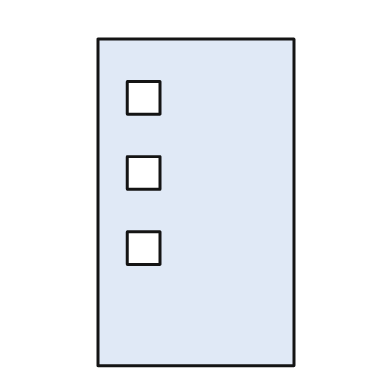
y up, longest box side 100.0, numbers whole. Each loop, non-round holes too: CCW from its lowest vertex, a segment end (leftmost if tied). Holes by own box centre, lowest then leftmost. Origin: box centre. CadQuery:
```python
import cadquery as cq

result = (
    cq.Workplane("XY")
    .moveTo(-30.0, -50.0)
    .lineTo(30.0, -50.0)
    .lineTo(30.0, 50.0)
    .lineTo(-30.0, 50.0)
    .close()
    .moveTo(-21.0, -19.0)
    .lineTo(-11.0, -19.0)
    .lineTo(-11.0, -9.0)
    .lineTo(-21.0, -9.0)
    .close()
    .moveTo(-21.0, 4.0)
    .lineTo(-11.0, 4.0)
    .lineTo(-11.0, 14.0)
    .lineTo(-21.0, 14.0)
    .close()
    .moveTo(-21.0, 27.0)
    .lineTo(-11.0, 27.0)
    .lineTo(-11.0, 37.0)
    .lineTo(-21.0, 37.0)
    .close()
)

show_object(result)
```